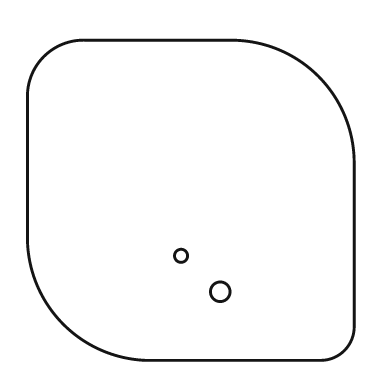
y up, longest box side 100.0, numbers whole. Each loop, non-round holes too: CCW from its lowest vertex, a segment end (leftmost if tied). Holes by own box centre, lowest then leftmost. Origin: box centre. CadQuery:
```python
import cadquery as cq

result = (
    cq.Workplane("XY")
    .moveTo(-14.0, -49.0)
    .lineTo(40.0, -49.0)
    .threePointArc((47.0, -46.0), (50.0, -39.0))
    .lineTo(50.0, 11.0)
    .threePointArc((39.0, 38.0), (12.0, 49.0))
    .lineTo(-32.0, 49.0)
    .threePointArc((-45.0, 44.0), (-50.0, 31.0))
    .lineTo(-50.0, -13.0)
    .threePointArc((-39.0, -38.0), (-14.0, -49.0))
    .close()
    .moveTo(9.0, -28.0)
    .circle(3.0)
    .moveTo(-3.0, -17.0)
    .circle(2.0)
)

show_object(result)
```